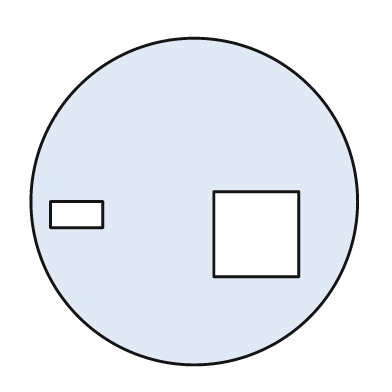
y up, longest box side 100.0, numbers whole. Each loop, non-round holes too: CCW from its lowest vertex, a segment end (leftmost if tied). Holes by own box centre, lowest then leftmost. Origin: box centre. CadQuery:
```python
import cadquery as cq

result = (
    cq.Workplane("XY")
    .moveTo(0.0, 0.0)
    .circle(50.0)
    .moveTo(6.0, -23.0)
    .lineTo(32.0, -23.0)
    .lineTo(32.0, 3.0)
    .lineTo(6.0, 3.0)
    .close()
    .moveTo(-44.0, -8.0)
    .lineTo(-28.0, -8.0)
    .lineTo(-28.0, 0.0)
    .lineTo(-44.0, 0.0)
    .close()
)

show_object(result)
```